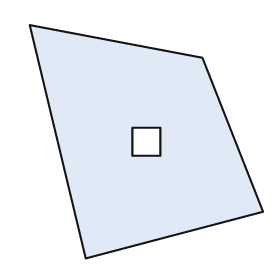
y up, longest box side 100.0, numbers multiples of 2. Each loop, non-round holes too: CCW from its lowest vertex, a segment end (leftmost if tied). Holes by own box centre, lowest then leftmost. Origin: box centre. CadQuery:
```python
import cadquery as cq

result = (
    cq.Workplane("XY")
    .moveTo(-26.0, -50.0)
    .lineTo(50.0, -30.0)
    .lineTo(24.0, 36.0)
    .lineTo(-50.0, 50.0)
    .close()
    .moveTo(-6.0, -6.0)
    .lineTo(6.0, -6.0)
    .lineTo(6.0, 6.0)
    .lineTo(-6.0, 6.0)
    .close()
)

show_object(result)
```